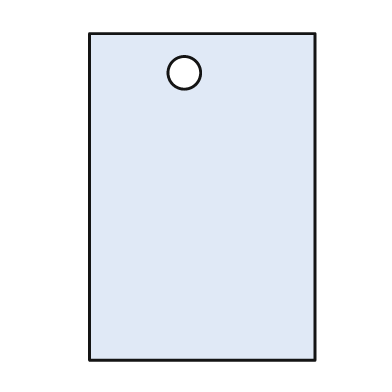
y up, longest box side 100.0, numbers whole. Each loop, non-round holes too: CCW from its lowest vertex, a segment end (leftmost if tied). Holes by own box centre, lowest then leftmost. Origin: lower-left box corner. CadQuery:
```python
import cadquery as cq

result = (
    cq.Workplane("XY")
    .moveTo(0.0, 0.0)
    .lineTo(69.0, 0.0)
    .lineTo(69.0, 100.0)
    .lineTo(0.0, 100.0)
    .close()
    .moveTo(29.0, 88.0)
    .circle(5.0)
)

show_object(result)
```